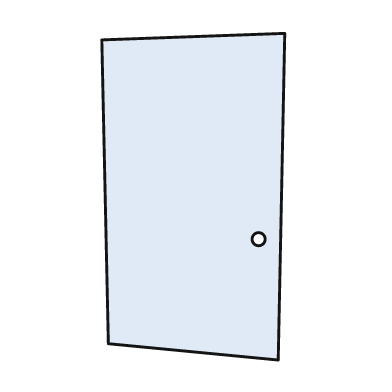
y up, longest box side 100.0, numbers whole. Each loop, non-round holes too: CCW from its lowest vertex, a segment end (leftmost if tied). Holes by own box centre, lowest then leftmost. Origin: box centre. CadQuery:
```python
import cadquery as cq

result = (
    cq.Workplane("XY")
    .moveTo(26.0, -50.0)
    .lineTo(28.0, 50.0)
    .lineTo(-28.0, 48.0)
    .lineTo(-26.0, -45.0)
    .close()
    .moveTo(20.0, -13.0)
    .circle(2.0)
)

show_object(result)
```